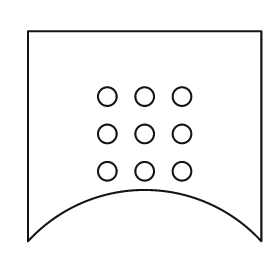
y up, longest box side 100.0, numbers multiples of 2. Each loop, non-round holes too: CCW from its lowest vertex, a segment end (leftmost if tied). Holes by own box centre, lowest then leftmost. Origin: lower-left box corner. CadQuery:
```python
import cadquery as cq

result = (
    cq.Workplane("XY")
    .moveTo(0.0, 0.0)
    .threePointArc((50.0, 22.0), (100.0, 0.0))
    .lineTo(100.0, 90.0)
    .lineTo(0.0, 90.0)
    .close()
    .moveTo(34.0, 30.0)
    .circle(4.0)
    .moveTo(50.0, 30.0)
    .circle(4.0)
    .moveTo(66.0, 30.0)
    .circle(4.0)
    .moveTo(34.0, 46.0)
    .circle(4.0)
    .moveTo(50.0, 46.0)
    .circle(4.0)
    .moveTo(66.0, 46.0)
    .circle(4.0)
    .moveTo(34.0, 62.0)
    .circle(4.0)
    .moveTo(50.0, 62.0)
    .circle(4.0)
    .moveTo(66.0, 62.0)
    .circle(4.0)
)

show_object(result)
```